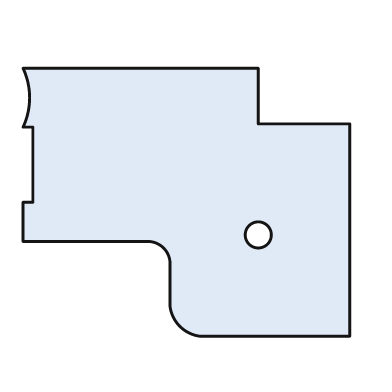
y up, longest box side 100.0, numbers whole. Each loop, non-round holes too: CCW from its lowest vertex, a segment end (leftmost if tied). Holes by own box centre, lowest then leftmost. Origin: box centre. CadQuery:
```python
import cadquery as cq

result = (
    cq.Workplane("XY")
    .moveTo(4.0, -41.0)
    .lineTo(50.0, -41.0)
    .lineTo(50.0, 24.0)
    .lineTo(22.0, 24.0)
    .lineTo(22.0, 41.0)
    .lineTo(-50.0, 41.0)
    .threePointArc((-48.0, 32.0), (-50.0, 23.0))
    .lineTo(-47.0, 23.0)
    .lineTo(-47.0, 0.0)
    .lineTo(-50.0, 0.0)
    .lineTo(-50.0, -12.0)
    .lineTo(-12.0, -12.0)
    .threePointArc((-7.0, -14.0), (-5.0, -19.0))
    .lineTo(-5.0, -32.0)
    .threePointArc((-2.0, -38.0), (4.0, -41.0))
    .close()
    .moveTo(22.0, -10.0)
    .circle(4.0)
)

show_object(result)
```